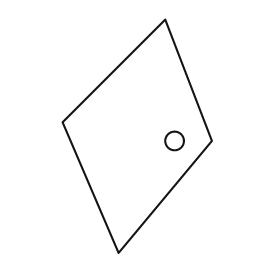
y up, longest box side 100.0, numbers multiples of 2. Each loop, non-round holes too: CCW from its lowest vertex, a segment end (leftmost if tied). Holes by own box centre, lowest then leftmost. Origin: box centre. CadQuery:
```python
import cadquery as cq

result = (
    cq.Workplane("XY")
    .moveTo(-8.0, -50.0)
    .lineTo(32.0, -2.0)
    .lineTo(12.0, 50.0)
    .lineTo(-32.0, 6.0)
    .close()
    .moveTo(16.0, -2.0)
    .circle(4.0)
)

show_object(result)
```